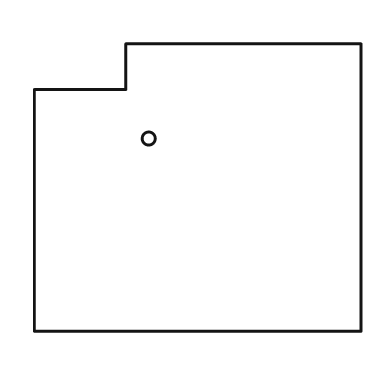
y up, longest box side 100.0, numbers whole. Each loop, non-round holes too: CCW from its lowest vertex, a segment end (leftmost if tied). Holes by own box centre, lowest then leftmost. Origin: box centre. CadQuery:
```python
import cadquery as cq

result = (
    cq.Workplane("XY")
    .moveTo(-50.0, -44.0)
    .lineTo(50.0, -44.0)
    .lineTo(50.0, 44.0)
    .lineTo(-22.0, 44.0)
    .lineTo(-22.0, 30.0)
    .lineTo(-50.0, 30.0)
    .close()
    .moveTo(-15.0, 15.0)
    .circle(2.0)
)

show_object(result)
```